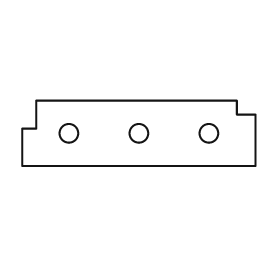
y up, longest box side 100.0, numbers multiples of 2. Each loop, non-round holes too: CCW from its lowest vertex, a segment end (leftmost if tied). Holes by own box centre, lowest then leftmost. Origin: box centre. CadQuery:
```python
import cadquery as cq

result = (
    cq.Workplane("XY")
    .moveTo(-50.0, -14.0)
    .lineTo(50.0, -14.0)
    .lineTo(50.0, 8.0)
    .lineTo(42.0, 8.0)
    .lineTo(42.0, 14.0)
    .lineTo(-44.0, 14.0)
    .lineTo(-44.0, 2.0)
    .lineTo(-50.0, 2.0)
    .close()
    .moveTo(-30.0, 0.0)
    .circle(4.0)
    .moveTo(0.0, 0.0)
    .circle(4.0)
    .moveTo(30.0, 0.0)
    .circle(4.0)
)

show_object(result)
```